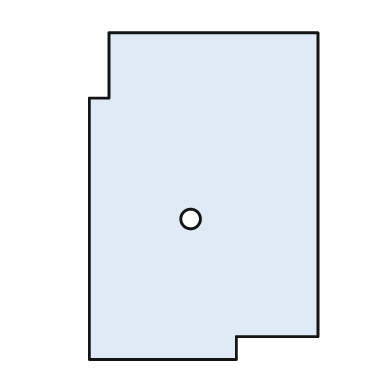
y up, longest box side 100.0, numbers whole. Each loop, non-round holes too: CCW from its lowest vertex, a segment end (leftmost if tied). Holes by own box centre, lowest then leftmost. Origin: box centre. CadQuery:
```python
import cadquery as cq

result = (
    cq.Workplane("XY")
    .moveTo(-35.0, -50.0)
    .lineTo(10.0, -50.0)
    .lineTo(10.0, -43.0)
    .lineTo(35.0, -43.0)
    .lineTo(35.0, 50.0)
    .lineTo(-29.0, 50.0)
    .lineTo(-29.0, 30.0)
    .lineTo(-35.0, 30.0)
    .close()
    .moveTo(-4.0, -7.0)
    .circle(3.0)
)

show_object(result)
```